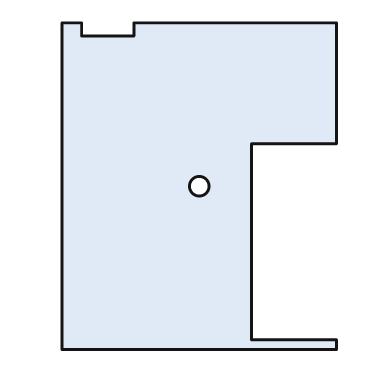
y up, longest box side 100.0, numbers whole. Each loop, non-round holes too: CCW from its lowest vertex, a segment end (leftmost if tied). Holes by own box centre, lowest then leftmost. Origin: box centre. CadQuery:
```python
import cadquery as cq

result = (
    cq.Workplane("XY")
    .moveTo(-42.0, -50.0)
    .lineTo(42.0, -50.0)
    .lineTo(42.0, -47.0)
    .lineTo(16.0, -47.0)
    .lineTo(16.0, 13.0)
    .lineTo(42.0, 13.0)
    .lineTo(42.0, 50.0)
    .lineTo(-20.0, 50.0)
    .lineTo(-20.0, 46.0)
    .lineTo(-36.0, 46.0)
    .lineTo(-36.0, 50.0)
    .lineTo(-42.0, 50.0)
    .close()
    .moveTo(0.0, 0.0)
    .circle(3.0)
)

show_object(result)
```